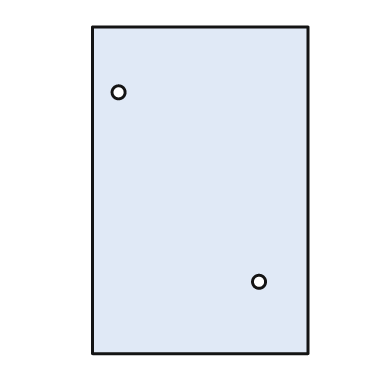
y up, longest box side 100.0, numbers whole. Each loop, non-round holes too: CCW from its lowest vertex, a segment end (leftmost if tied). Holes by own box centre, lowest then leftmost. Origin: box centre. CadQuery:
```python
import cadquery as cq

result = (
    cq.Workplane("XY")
    .moveTo(-33.0, -50.0)
    .lineTo(33.0, -50.0)
    .lineTo(33.0, 50.0)
    .lineTo(-33.0, 50.0)
    .close()
    .moveTo(18.0, -28.0)
    .circle(2.0)
    .moveTo(-25.0, 30.0)
    .circle(2.0)
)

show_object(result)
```